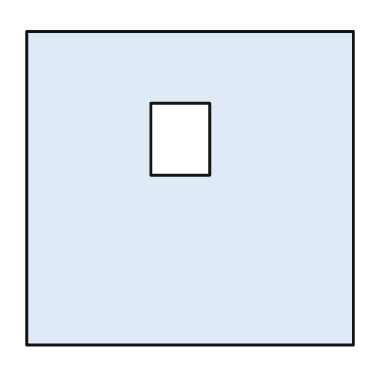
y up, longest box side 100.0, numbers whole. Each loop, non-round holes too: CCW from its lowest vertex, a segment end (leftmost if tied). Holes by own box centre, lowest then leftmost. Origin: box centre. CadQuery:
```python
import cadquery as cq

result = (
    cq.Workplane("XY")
    .moveTo(-50.0, -48.0)
    .lineTo(50.0, -48.0)
    .lineTo(50.0, 48.0)
    .lineTo(-50.0, 48.0)
    .close()
    .moveTo(-12.0, 4.0)
    .lineTo(6.0, 4.0)
    .lineTo(6.0, 26.0)
    .lineTo(-12.0, 26.0)
    .close()
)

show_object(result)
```